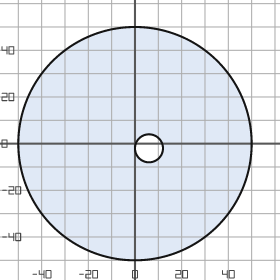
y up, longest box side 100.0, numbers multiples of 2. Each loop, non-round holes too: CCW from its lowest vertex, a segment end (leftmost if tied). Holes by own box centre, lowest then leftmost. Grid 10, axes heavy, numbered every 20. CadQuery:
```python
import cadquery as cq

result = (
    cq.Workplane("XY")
    .moveTo(0.0, 0.0)
    .circle(50.0)
    .moveTo(6.0, -2.0)
    .circle(6.0)
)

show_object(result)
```